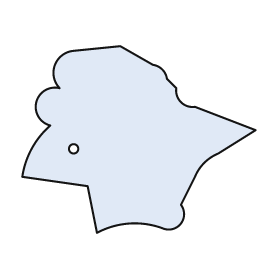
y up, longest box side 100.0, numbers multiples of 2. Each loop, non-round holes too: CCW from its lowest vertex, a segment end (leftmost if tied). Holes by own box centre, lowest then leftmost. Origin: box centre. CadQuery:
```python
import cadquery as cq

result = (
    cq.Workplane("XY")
    .moveTo(-18.0, -40.0)
    .threePointArc((-4.0, -36.0), (10.0, -38.0))
    .threePointArc((18.0, -36.0), (18.0, -28.0))
    .lineTo(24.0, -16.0)
    .threePointArc((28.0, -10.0), (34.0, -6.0))
    .lineTo(50.0, 4.0)
    .lineTo(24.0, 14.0)
    .threePointArc((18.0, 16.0), (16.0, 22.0))
    .lineTo(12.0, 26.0)
    .threePointArc((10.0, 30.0), (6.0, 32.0))
    .lineTo(-8.0, 40.0)
    .lineTo(-28.0, 38.0)
    .threePointArc((-36.0, 32.0), (-34.0, 22.0))
    .threePointArc((-44.0, 16.0), (-38.0, 6.0))
    .threePointArc((-46.0, -4.0), (-50.0, -16.0))
    .lineTo(-22.0, -20.0)
    .close()
    .moveTo(-28.0, -4.0)
    .circle(2.0)
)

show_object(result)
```